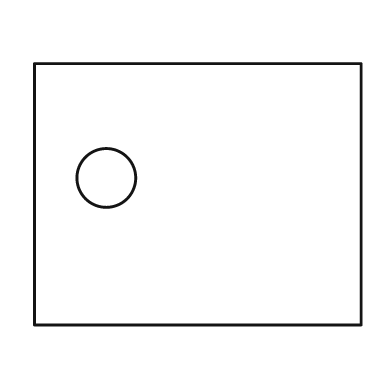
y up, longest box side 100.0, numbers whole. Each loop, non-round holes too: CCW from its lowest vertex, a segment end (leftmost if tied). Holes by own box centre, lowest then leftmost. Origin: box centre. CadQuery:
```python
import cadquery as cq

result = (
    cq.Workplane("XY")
    .moveTo(-50.0, -40.0)
    .lineTo(50.0, -40.0)
    .lineTo(50.0, 40.0)
    .lineTo(-50.0, 40.0)
    .close()
    .moveTo(-28.0, 5.0)
    .circle(9.0)
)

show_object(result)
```